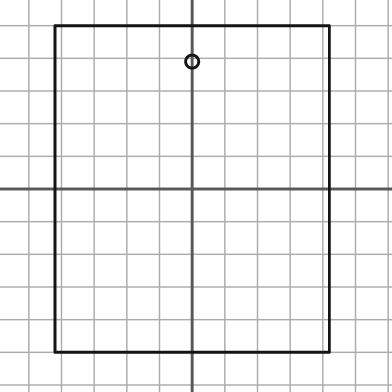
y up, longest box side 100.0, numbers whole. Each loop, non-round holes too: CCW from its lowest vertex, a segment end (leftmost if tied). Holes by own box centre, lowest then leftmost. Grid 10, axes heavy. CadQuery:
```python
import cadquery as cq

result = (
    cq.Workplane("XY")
    .moveTo(-42.0, -50.0)
    .lineTo(42.0, -50.0)
    .lineTo(42.0, 50.0)
    .lineTo(-42.0, 50.0)
    .close()
    .moveTo(0.0, 39.0)
    .circle(2.0)
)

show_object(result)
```